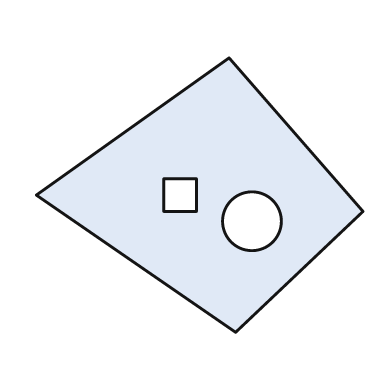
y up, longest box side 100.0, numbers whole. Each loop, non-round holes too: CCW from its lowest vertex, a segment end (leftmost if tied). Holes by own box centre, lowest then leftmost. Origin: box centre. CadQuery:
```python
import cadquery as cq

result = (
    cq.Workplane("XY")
    .moveTo(11.0, -42.0)
    .lineTo(50.0, -5.0)
    .lineTo(9.0, 42.0)
    .lineTo(-50.0, 0.0)
    .close()
    .moveTo(16.0, -8.0)
    .circle(9.0)
    .moveTo(-11.0, -5.0)
    .lineTo(-1.0, -5.0)
    .lineTo(-1.0, 5.0)
    .lineTo(-11.0, 5.0)
    .close()
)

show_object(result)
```